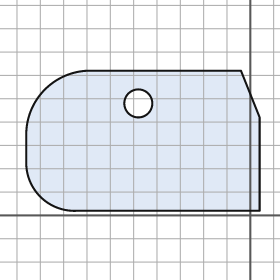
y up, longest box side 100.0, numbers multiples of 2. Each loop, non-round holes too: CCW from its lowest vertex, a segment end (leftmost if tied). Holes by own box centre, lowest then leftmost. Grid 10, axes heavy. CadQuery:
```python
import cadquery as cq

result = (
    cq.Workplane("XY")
    .moveTo(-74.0, 2.0)
    .lineTo(4.0, 2.0)
    .lineTo(4.0, 42.0)
    .lineTo(-4.0, 62.0)
    .lineTo(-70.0, 62.0)
    .threePointArc((-88.0, 54.0), (-96.0, 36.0))
    .lineTo(-96.0, 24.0)
    .threePointArc((-90.0, 8.0), (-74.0, 2.0))
    .close()
    .moveTo(-48.0, 48.0)
    .circle(6.0)
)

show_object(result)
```